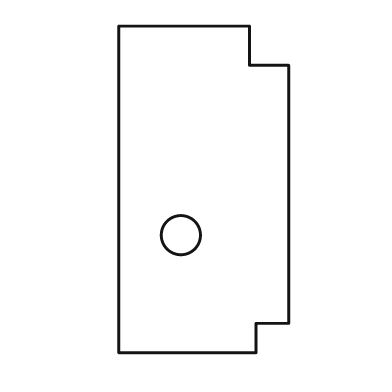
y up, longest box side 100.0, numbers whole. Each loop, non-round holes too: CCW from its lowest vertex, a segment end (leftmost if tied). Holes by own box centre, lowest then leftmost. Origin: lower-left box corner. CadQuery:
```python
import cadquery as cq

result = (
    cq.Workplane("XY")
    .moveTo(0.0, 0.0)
    .lineTo(42.0, 0.0)
    .lineTo(42.0, 9.0)
    .lineTo(52.0, 9.0)
    .lineTo(52.0, 88.0)
    .lineTo(40.0, 88.0)
    .lineTo(40.0, 100.0)
    .lineTo(0.0, 100.0)
    .close()
    .moveTo(19.0, 36.0)
    .circle(6.0)
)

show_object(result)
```